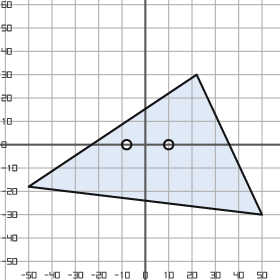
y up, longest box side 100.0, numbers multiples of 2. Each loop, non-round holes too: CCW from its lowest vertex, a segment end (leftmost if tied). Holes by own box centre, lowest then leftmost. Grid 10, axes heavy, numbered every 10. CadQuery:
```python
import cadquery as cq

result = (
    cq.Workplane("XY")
    .moveTo(50.0, -30.0)
    .lineTo(22.0, 30.0)
    .lineTo(-50.0, -18.0)
    .close()
    .moveTo(-8.0, 0.0)
    .circle(2.0)
    .moveTo(10.0, 0.0)
    .circle(2.0)
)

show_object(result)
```